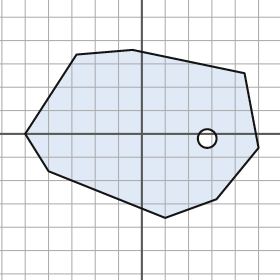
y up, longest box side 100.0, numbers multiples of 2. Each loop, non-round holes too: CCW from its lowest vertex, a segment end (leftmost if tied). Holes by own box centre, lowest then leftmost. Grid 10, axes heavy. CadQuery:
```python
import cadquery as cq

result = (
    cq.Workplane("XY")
    .moveTo(10.0, -36.0)
    .lineTo(32.0, -28.0)
    .lineTo(50.0, -6.0)
    .lineTo(44.0, 26.0)
    .lineTo(-4.0, 36.0)
    .lineTo(-28.0, 34.0)
    .lineTo(-50.0, 0.0)
    .lineTo(-40.0, -16.0)
    .close()
    .moveTo(28.0, -2.0)
    .circle(4.0)
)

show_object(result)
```